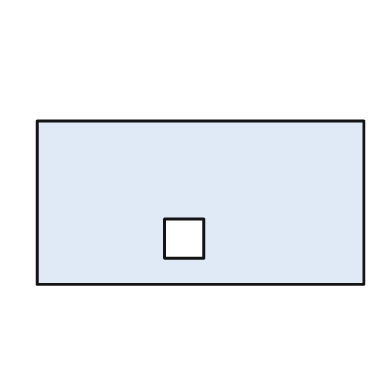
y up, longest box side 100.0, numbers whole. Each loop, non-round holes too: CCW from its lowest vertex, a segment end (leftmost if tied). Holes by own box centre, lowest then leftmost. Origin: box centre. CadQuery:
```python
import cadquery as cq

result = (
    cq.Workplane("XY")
    .moveTo(-50.0, -25.0)
    .lineTo(50.0, -25.0)
    .lineTo(50.0, 25.0)
    .lineTo(-50.0, 25.0)
    .close()
    .moveTo(-11.0, -17.0)
    .lineTo(1.0, -17.0)
    .lineTo(1.0, -5.0)
    .lineTo(-11.0, -5.0)
    .close()
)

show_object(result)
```